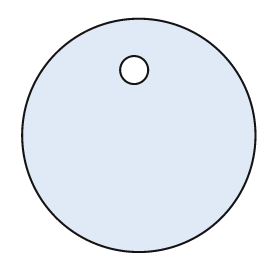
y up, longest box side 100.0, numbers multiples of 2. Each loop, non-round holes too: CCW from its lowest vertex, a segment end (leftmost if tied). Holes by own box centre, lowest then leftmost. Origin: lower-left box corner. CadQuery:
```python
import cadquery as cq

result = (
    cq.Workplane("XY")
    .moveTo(50.0, 50.0)
    .circle(50.0)
    .moveTo(48.0, 78.0)
    .circle(6.0)
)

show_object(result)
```